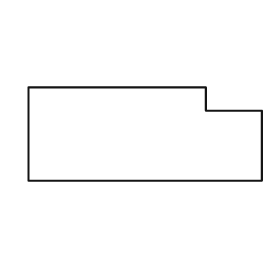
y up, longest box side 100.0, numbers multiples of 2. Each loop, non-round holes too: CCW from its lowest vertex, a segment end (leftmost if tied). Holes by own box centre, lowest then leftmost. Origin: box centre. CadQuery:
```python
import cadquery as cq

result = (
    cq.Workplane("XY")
    .moveTo(-50.0, -20.0)
    .lineTo(50.0, -20.0)
    .lineTo(50.0, 10.0)
    .lineTo(26.0, 10.0)
    .lineTo(26.0, 20.0)
    .lineTo(-50.0, 20.0)
    .close()
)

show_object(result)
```